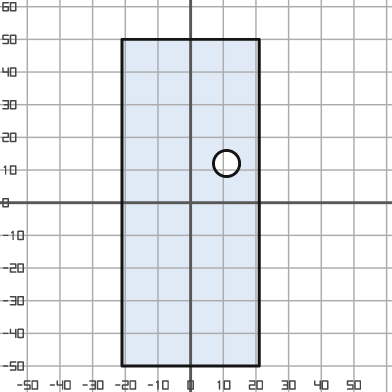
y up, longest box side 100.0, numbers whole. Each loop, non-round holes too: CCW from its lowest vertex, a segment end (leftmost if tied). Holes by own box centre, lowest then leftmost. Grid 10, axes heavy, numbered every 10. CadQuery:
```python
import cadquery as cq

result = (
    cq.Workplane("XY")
    .moveTo(-21.0, -50.0)
    .lineTo(21.0, -50.0)
    .lineTo(21.0, 50.0)
    .lineTo(-21.0, 50.0)
    .close()
    .moveTo(11.0, 12.0)
    .circle(4.0)
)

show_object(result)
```